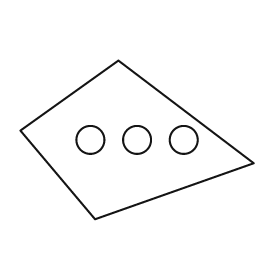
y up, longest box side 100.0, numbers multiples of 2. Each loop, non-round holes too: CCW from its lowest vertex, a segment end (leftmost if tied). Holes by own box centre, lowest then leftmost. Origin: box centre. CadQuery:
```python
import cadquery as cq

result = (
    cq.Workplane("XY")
    .moveTo(-18.0, -34.0)
    .lineTo(50.0, -10.0)
    .lineTo(-8.0, 34.0)
    .lineTo(-50.0, 4.0)
    .close()
    .moveTo(-20.0, 0.0)
    .circle(6.0)
    .moveTo(0.0, 0.0)
    .circle(6.0)
    .moveTo(20.0, 0.0)
    .circle(6.0)
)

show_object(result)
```